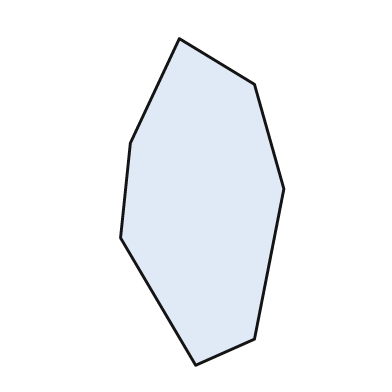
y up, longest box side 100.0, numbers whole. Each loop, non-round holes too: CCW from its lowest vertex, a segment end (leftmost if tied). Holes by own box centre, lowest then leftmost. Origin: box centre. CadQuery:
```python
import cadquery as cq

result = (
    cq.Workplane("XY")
    .moveTo(-2.0, -50.0)
    .lineTo(16.0, -42.0)
    .lineTo(25.0, 4.0)
    .lineTo(16.0, 36.0)
    .lineTo(-7.0, 50.0)
    .lineTo(-22.0, 18.0)
    .lineTo(-25.0, -11.0)
    .close()
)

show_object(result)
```